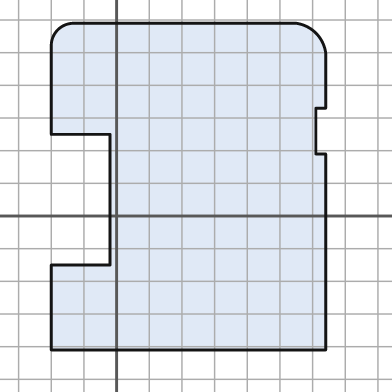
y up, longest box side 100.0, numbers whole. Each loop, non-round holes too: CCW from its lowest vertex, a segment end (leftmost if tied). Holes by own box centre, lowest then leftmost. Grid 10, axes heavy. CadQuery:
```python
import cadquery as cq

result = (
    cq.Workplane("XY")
    .moveTo(-20.0, -41.0)
    .lineTo(64.0, -41.0)
    .lineTo(64.0, 19.0)
    .lineTo(61.0, 19.0)
    .lineTo(61.0, 33.0)
    .lineTo(64.0, 33.0)
    .lineTo(64.0, 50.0)
    .threePointArc((61.0, 56.0), (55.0, 59.0))
    .lineTo(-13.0, 59.0)
    .threePointArc((-18.0, 57.0), (-20.0, 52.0))
    .lineTo(-20.0, 25.0)
    .lineTo(-2.0, 25.0)
    .lineTo(-2.0, -15.0)
    .lineTo(-20.0, -15.0)
    .close()
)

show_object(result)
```